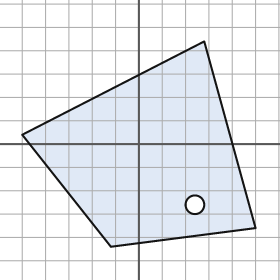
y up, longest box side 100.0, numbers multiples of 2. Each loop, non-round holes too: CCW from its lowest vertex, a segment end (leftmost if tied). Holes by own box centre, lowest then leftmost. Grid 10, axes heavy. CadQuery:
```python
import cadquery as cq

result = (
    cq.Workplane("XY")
    .moveTo(-12.0, -44.0)
    .lineTo(50.0, -36.0)
    .lineTo(28.0, 44.0)
    .lineTo(-50.0, 4.0)
    .close()
    .moveTo(24.0, -26.0)
    .circle(4.0)
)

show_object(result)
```